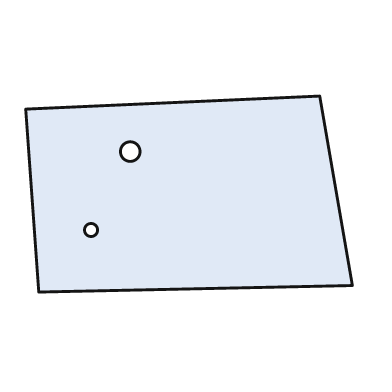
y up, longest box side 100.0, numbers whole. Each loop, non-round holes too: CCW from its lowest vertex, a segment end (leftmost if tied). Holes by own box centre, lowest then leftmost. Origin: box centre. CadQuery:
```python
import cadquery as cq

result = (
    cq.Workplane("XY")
    .moveTo(-46.0, -30.0)
    .lineTo(50.0, -28.0)
    .lineTo(40.0, 30.0)
    .lineTo(-50.0, 26.0)
    .close()
    .moveTo(-30.0, -11.0)
    .circle(2.0)
    .moveTo(-18.0, 13.0)
    .circle(3.0)
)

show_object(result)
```